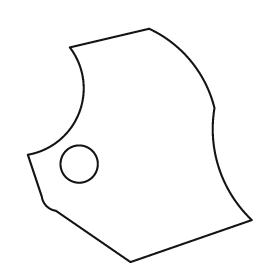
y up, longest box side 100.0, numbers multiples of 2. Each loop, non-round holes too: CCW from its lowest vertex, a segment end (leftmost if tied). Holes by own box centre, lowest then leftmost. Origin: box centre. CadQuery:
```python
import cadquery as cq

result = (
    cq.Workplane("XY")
    .moveTo(-4.0, -50.0)
    .lineTo(48.0, -32.0)
    .threePointArc((34.0, -10.0), (32.0, 16.0))
    .threePointArc((22.0, 36.0), (4.0, 50.0))
    .lineTo(-30.0, 42.0)
    .threePointArc((-26.0, 14.0), (-48.0, -4.0))
    .lineTo(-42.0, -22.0)
    .threePointArc((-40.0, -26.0), (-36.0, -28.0))
    .close()
    .moveTo(-26.0, -8.0)
    .circle(8.0)
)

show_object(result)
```